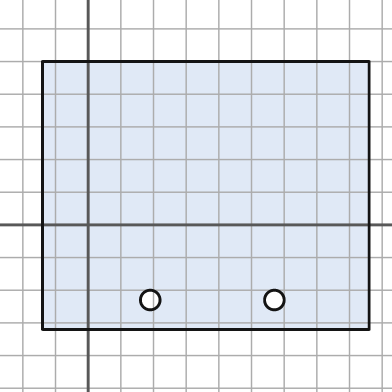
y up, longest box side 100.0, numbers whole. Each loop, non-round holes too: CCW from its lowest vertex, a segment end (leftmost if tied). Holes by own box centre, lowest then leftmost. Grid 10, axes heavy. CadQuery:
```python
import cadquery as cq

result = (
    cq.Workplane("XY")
    .moveTo(-14.0, -32.0)
    .lineTo(86.0, -32.0)
    .lineTo(86.0, 50.0)
    .lineTo(-14.0, 50.0)
    .close()
    .moveTo(19.0, -23.0)
    .circle(3.0)
    .moveTo(57.0, -23.0)
    .circle(3.0)
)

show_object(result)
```